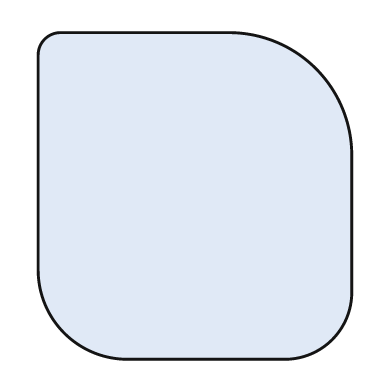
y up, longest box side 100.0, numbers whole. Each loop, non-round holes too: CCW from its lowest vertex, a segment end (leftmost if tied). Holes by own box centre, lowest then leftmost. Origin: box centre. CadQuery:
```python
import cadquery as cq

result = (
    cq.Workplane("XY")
    .moveTo(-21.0, -50.0)
    .lineTo(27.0, -50.0)
    .threePointArc((42.0, -44.0), (48.0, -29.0))
    .lineTo(48.0, 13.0)
    .threePointArc((37.0, 39.0), (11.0, 50.0))
    .lineTo(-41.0, 50.0)
    .threePointArc((-46.0, 48.0), (-48.0, 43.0))
    .lineTo(-48.0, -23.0)
    .threePointArc((-40.0, -42.0), (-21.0, -50.0))
    .close()
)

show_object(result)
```